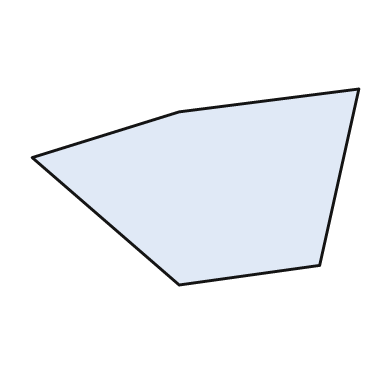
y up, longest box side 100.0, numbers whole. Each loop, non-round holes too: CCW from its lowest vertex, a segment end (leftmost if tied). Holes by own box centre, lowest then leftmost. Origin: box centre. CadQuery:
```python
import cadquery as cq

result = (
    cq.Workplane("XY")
    .moveTo(-5.0, -30.0)
    .lineTo(38.0, -24.0)
    .lineTo(50.0, 30.0)
    .lineTo(-5.0, 23.0)
    .lineTo(-50.0, 9.0)
    .close()
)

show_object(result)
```